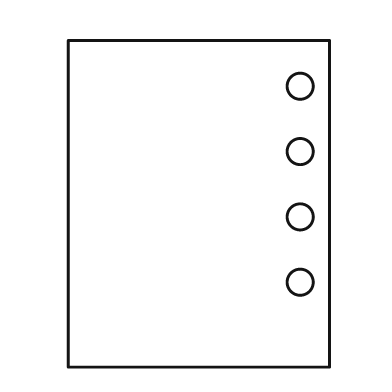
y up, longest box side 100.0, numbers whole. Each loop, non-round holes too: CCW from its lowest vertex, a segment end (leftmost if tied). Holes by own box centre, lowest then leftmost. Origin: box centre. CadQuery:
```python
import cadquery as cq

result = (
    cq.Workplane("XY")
    .moveTo(-40.0, -50.0)
    .lineTo(40.0, -50.0)
    .lineTo(40.0, 50.0)
    .lineTo(-40.0, 50.0)
    .close()
    .moveTo(31.0, -24.0)
    .circle(4.0)
    .moveTo(31.0, -4.0)
    .circle(4.0)
    .moveTo(31.0, 16.0)
    .circle(4.0)
    .moveTo(31.0, 36.0)
    .circle(4.0)
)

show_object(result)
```